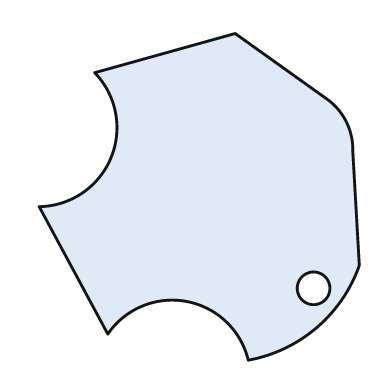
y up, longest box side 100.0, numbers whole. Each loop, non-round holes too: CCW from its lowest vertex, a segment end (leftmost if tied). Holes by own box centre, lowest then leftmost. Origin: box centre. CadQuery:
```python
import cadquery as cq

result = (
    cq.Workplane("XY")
    .moveTo(15.0, -50.0)
    .threePointArc((36.0, -40.0), (49.0, -21.0))
    .lineTo(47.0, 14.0)
    .threePointArc((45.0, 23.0), (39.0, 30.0))
    .lineTo(11.0, 50.0)
    .lineTo(-32.0, 38.0)
    .threePointArc((-27.0, 12.0), (-49.0, -3.0))
    .lineTo(-28.0, -42.0)
    .threePointArc((-4.0, -32.0), (15.0, -50.0))
    .close()
    .moveTo(35.0, -28.0)
    .circle(5.0)
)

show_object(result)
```